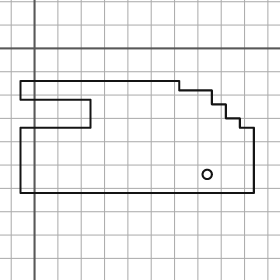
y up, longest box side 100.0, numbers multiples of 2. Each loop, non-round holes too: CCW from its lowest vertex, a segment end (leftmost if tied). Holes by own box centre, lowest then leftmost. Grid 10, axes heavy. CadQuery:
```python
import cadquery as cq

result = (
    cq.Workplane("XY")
    .moveTo(-6.0, -62.0)
    .lineTo(94.0, -62.0)
    .lineTo(94.0, -34.0)
    .lineTo(88.0, -34.0)
    .lineTo(88.0, -30.0)
    .lineTo(82.0, -30.0)
    .lineTo(82.0, -24.0)
    .lineTo(76.0, -24.0)
    .lineTo(76.0, -18.0)
    .lineTo(62.0, -18.0)
    .lineTo(62.0, -14.0)
    .lineTo(-6.0, -14.0)
    .lineTo(-6.0, -22.0)
    .lineTo(24.0, -22.0)
    .lineTo(24.0, -34.0)
    .lineTo(-6.0, -34.0)
    .close()
    .moveTo(74.0, -54.0)
    .circle(2.0)
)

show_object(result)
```